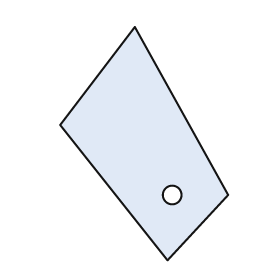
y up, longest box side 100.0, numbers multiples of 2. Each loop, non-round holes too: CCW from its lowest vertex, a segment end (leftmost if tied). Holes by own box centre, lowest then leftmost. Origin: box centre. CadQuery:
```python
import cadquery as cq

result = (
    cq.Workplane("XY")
    .moveTo(10.0, -50.0)
    .lineTo(36.0, -22.0)
    .lineTo(-4.0, 50.0)
    .lineTo(-36.0, 8.0)
    .close()
    .moveTo(12.0, -22.0)
    .circle(4.0)
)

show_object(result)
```